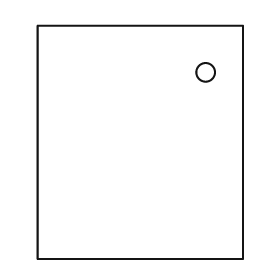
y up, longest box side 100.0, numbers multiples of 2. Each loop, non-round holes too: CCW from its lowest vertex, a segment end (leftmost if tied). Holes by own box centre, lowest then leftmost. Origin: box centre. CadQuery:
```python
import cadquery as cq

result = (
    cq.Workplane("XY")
    .moveTo(-44.0, -50.0)
    .lineTo(44.0, -50.0)
    .lineTo(44.0, 50.0)
    .lineTo(-44.0, 50.0)
    .close()
    .moveTo(28.0, 30.0)
    .circle(4.0)
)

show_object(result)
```